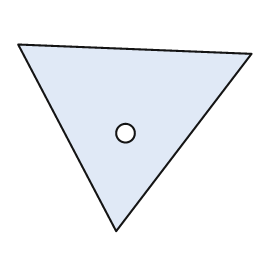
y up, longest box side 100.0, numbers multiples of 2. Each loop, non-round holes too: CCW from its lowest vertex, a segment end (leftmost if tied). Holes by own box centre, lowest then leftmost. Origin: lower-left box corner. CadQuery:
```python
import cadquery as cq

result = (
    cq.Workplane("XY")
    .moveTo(42.0, 0.0)
    .lineTo(100.0, 76.0)
    .lineTo(0.0, 80.0)
    .close()
    .moveTo(46.0, 42.0)
    .circle(4.0)
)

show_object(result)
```